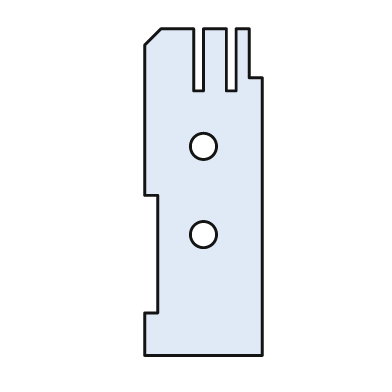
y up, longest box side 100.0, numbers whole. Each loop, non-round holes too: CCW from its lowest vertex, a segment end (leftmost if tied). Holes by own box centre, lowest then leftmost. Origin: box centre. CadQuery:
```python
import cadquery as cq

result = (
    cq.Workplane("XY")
    .moveTo(-18.0, -50.0)
    .lineTo(18.0, -50.0)
    .lineTo(18.0, 35.0)
    .lineTo(14.0, 35.0)
    .lineTo(14.0, 50.0)
    .lineTo(10.0, 50.0)
    .lineTo(10.0, 31.0)
    .lineTo(7.0, 31.0)
    .lineTo(7.0, 50.0)
    .lineTo(0.0, 50.0)
    .lineTo(0.0, 31.0)
    .lineTo(-3.0, 31.0)
    .lineTo(-3.0, 50.0)
    .lineTo(-13.0, 50.0)
    .lineTo(-18.0, 45.0)
    .lineTo(-18.0, -1.0)
    .lineTo(-14.0, -1.0)
    .lineTo(-14.0, -37.0)
    .lineTo(-18.0, -37.0)
    .close()
    .moveTo(0.0, -13.0)
    .circle(4.0)
    .moveTo(0.0, 14.0)
    .circle(4.0)
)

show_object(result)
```